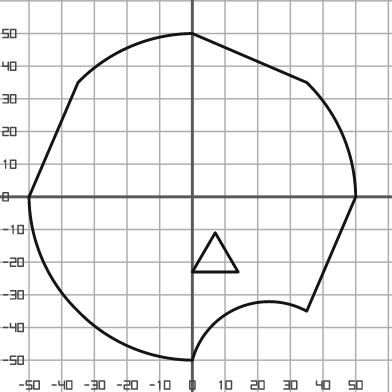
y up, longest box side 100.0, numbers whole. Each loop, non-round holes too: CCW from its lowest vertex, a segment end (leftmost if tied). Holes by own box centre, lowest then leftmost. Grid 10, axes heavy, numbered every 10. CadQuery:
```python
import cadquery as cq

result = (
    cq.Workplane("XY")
    .moveTo(0.0, -50.0)
    .threePointArc((14.0, -34.0), (35.0, -35.0))
    .lineTo(50.0, 0.0)
    .threePointArc((46.0, 19.0), (35.0, 35.0))
    .lineTo(0.0, 50.0)
    .threePointArc((-19.0, 46.0), (-35.0, 35.0))
    .lineTo(-50.0, 0.0)
    .threePointArc((-46.0, -19.0), (-35.0, -35.0))
    .threePointArc((-19.0, -46.0), (0.0, -50.0))
    .close()
    .moveTo(0.0, -23.0)
    .lineTo(14.0, -23.0)
    .lineTo(7.0, -11.0)
    .close()
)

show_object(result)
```